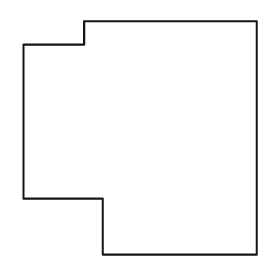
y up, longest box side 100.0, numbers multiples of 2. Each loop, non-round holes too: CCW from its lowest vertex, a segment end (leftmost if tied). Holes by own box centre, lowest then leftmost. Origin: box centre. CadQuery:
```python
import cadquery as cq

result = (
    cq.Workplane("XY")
    .moveTo(-16.0, -50.0)
    .lineTo(50.0, -50.0)
    .lineTo(50.0, 50.0)
    .lineTo(-24.0, 50.0)
    .lineTo(-24.0, 40.0)
    .lineTo(-50.0, 40.0)
    .lineTo(-50.0, -26.0)
    .lineTo(-16.0, -26.0)
    .close()
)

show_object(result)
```